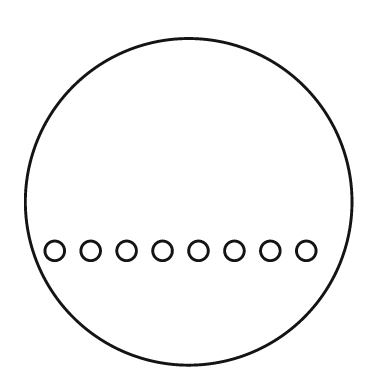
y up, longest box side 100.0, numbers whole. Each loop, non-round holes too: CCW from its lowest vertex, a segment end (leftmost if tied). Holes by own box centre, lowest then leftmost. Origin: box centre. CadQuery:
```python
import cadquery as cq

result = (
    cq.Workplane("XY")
    .moveTo(0.0, 0.0)
    .circle(50.0)
    .moveTo(-41.0, -15.0)
    .circle(3.0)
    .moveTo(-30.0, -15.0)
    .circle(3.0)
    .moveTo(-19.0, -15.0)
    .circle(3.0)
    .moveTo(-8.0, -15.0)
    .circle(3.0)
    .moveTo(3.0, -15.0)
    .circle(3.0)
    .moveTo(14.0, -15.0)
    .circle(3.0)
    .moveTo(25.0, -15.0)
    .circle(3.0)
    .moveTo(36.0, -15.0)
    .circle(3.0)
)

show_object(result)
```